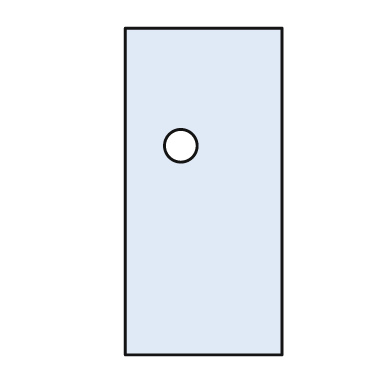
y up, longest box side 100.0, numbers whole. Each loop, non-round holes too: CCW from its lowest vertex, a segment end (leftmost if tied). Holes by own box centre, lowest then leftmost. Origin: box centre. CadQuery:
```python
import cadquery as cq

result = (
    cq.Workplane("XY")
    .moveTo(-24.0, -50.0)
    .lineTo(24.0, -50.0)
    .lineTo(24.0, 50.0)
    .lineTo(-24.0, 50.0)
    .close()
    .moveTo(-7.0, 14.0)
    .circle(5.0)
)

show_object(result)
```